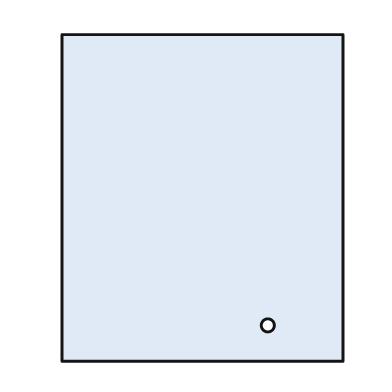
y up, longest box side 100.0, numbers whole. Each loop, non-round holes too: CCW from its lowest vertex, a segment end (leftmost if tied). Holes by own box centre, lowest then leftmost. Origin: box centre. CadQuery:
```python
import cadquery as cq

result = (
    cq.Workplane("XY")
    .moveTo(-43.0, -50.0)
    .lineTo(43.0, -50.0)
    .lineTo(43.0, 50.0)
    .lineTo(-43.0, 50.0)
    .close()
    .moveTo(20.0, -39.0)
    .circle(2.0)
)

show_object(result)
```